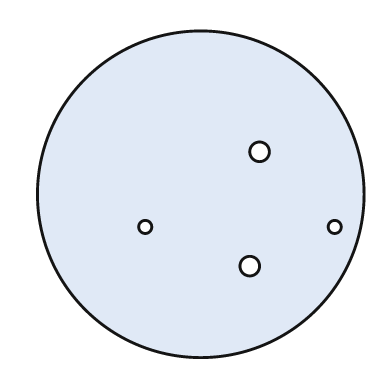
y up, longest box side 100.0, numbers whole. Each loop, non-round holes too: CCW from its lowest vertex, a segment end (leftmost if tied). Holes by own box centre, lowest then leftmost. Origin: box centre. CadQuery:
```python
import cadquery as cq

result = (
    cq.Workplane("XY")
    .moveTo(0.0, 0.0)
    .circle(50.0)
    .moveTo(15.0, -22.0)
    .circle(3.0)
    .moveTo(-17.0, -10.0)
    .circle(2.0)
    .moveTo(41.0, -10.0)
    .circle(2.0)
    .moveTo(18.0, 13.0)
    .circle(3.0)
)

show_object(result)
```